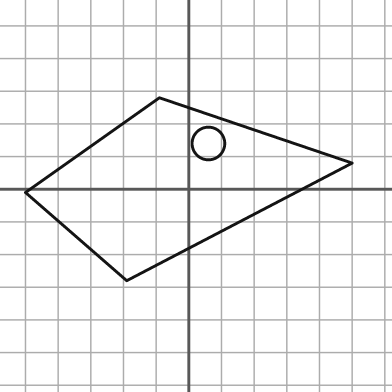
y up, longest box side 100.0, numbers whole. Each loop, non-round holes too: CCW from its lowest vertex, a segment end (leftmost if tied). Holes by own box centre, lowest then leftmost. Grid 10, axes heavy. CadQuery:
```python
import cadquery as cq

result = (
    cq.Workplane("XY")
    .moveTo(-19.0, -28.0)
    .lineTo(50.0, 8.0)
    .lineTo(-9.0, 28.0)
    .lineTo(-50.0, -1.0)
    .close()
    .moveTo(6.0, 14.0)
    .circle(5.0)
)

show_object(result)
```